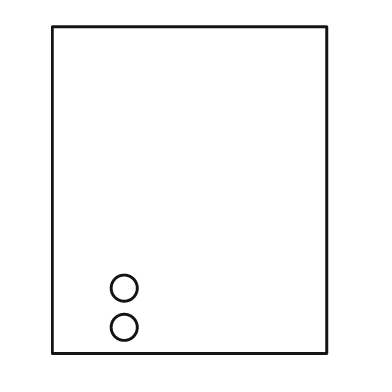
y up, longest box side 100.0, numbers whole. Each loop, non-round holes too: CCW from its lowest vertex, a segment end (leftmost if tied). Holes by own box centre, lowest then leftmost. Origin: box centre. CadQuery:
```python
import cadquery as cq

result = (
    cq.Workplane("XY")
    .moveTo(-42.0, -50.0)
    .lineTo(42.0, -50.0)
    .lineTo(42.0, 50.0)
    .lineTo(-42.0, 50.0)
    .close()
    .moveTo(-20.0, -42.0)
    .circle(4.0)
    .moveTo(-20.0, -30.0)
    .circle(4.0)
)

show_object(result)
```